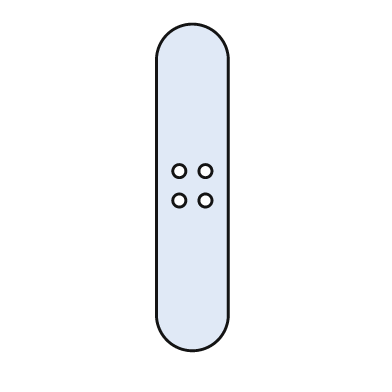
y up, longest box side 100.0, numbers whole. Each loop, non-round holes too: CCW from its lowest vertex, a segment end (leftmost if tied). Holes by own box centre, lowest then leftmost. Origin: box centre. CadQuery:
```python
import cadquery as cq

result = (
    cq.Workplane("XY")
    .moveTo(-11.0, -39.0)
    .threePointArc((0.0, -50.0), (11.0, -39.0))
    .lineTo(11.0, 39.0)
    .threePointArc((0.0, 50.0), (-11.0, 39.0))
    .close()
    .moveTo(-4.0, -4.0)
    .circle(2.0)
    .moveTo(4.0, -4.0)
    .circle(2.0)
    .moveTo(-4.0, 5.0)
    .circle(2.0)
    .moveTo(4.0, 5.0)
    .circle(2.0)
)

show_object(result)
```